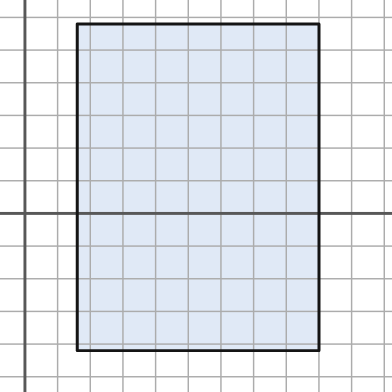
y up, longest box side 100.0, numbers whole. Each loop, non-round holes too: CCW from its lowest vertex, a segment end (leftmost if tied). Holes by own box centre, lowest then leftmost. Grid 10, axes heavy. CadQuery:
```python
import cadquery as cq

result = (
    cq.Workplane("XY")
    .moveTo(16.0, -42.0)
    .lineTo(90.0, -42.0)
    .lineTo(90.0, 58.0)
    .lineTo(16.0, 58.0)
    .close()
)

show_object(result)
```